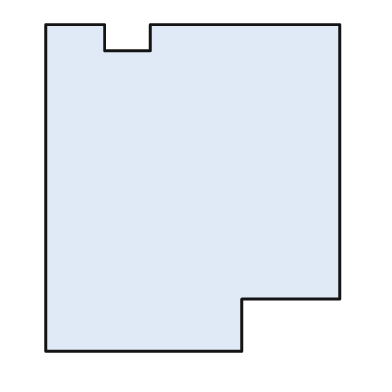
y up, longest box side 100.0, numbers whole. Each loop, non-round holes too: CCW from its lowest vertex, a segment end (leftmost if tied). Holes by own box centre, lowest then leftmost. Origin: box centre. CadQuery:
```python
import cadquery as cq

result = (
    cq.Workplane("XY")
    .moveTo(-45.0, -50.0)
    .lineTo(15.0, -50.0)
    .lineTo(15.0, -34.0)
    .lineTo(45.0, -34.0)
    .lineTo(45.0, 50.0)
    .lineTo(-13.0, 50.0)
    .lineTo(-13.0, 42.0)
    .lineTo(-27.0, 42.0)
    .lineTo(-27.0, 50.0)
    .lineTo(-45.0, 50.0)
    .close()
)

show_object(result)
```